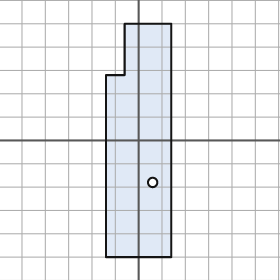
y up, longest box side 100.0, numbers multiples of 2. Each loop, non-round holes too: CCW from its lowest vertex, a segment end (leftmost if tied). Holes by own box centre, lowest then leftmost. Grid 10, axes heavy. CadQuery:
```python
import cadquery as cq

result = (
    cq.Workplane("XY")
    .moveTo(-14.0, -50.0)
    .lineTo(14.0, -50.0)
    .lineTo(14.0, 50.0)
    .lineTo(-6.0, 50.0)
    .lineTo(-6.0, 28.0)
    .lineTo(-14.0, 28.0)
    .close()
    .moveTo(6.0, -18.0)
    .circle(2.0)
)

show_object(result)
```